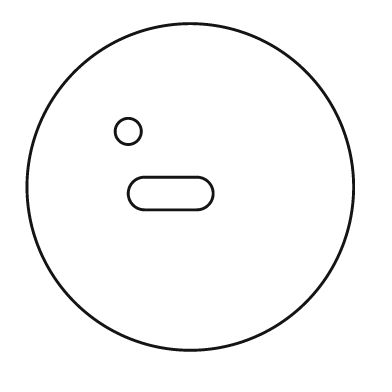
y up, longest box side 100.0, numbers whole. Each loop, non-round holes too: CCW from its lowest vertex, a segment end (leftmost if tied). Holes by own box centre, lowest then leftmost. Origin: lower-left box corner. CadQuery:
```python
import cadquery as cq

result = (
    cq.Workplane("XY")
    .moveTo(50.0, 50.0)
    .circle(50.0)
    .moveTo(36.0, 43.0)
    .lineTo(52.0, 43.0)
    .threePointArc((57.0, 48.0), (52.0, 53.0))
    .lineTo(36.0, 53.0)
    .threePointArc((31.0, 48.0), (36.0, 43.0))
    .close()
    .moveTo(31.0, 67.0)
    .circle(4.0)
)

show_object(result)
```